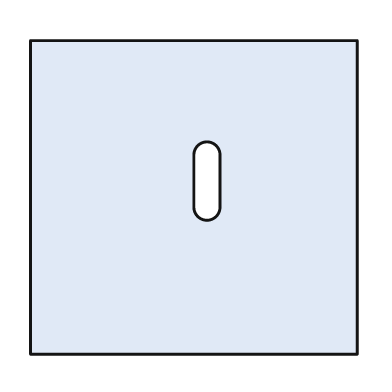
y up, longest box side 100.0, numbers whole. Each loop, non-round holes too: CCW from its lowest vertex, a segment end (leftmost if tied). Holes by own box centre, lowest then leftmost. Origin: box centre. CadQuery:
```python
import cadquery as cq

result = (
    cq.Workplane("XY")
    .moveTo(-50.0, -48.0)
    .lineTo(50.0, -48.0)
    .lineTo(50.0, 48.0)
    .lineTo(-50.0, 48.0)
    .close()
    .moveTo(0.0, -3.0)
    .threePointArc((4.0, -7.0), (8.0, -3.0))
    .lineTo(8.0, 13.0)
    .threePointArc((4.0, 17.0), (0.0, 13.0))
    .close()
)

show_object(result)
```